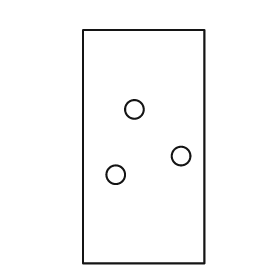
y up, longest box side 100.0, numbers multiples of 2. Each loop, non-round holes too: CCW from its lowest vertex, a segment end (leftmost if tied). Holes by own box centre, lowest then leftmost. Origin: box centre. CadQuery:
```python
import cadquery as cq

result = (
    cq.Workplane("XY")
    .moveTo(-26.0, -50.0)
    .lineTo(26.0, -50.0)
    .lineTo(26.0, 50.0)
    .lineTo(-26.0, 50.0)
    .close()
    .moveTo(-12.0, -12.0)
    .circle(4.0)
    .moveTo(16.0, -4.0)
    .circle(4.0)
    .moveTo(-4.0, 16.0)
    .circle(4.0)
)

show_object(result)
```